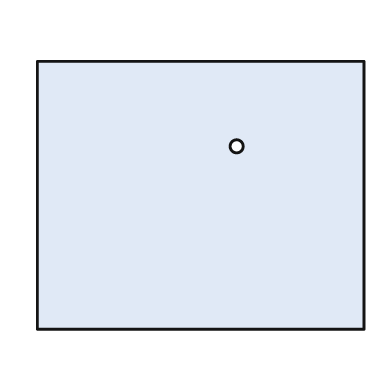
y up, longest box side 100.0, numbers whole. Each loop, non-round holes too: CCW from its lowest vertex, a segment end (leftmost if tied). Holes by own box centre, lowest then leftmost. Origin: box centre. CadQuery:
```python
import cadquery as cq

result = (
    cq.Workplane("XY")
    .moveTo(-50.0, -41.0)
    .lineTo(50.0, -41.0)
    .lineTo(50.0, 41.0)
    .lineTo(-50.0, 41.0)
    .close()
    .moveTo(11.0, 15.0)
    .circle(2.0)
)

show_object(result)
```